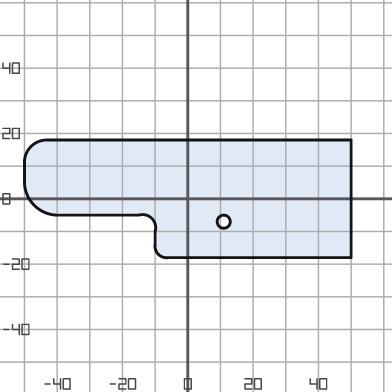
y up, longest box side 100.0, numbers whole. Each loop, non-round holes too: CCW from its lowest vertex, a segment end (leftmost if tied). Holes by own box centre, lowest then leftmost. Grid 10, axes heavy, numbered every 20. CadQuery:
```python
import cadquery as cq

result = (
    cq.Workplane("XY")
    .moveTo(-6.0, -18.0)
    .lineTo(50.0, -18.0)
    .lineTo(50.0, 18.0)
    .lineTo(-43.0, 18.0)
    .threePointArc((-48.0, 16.0), (-50.0, 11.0))
    .lineTo(-50.0, 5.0)
    .threePointArc((-47.0, -2.0), (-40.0, -5.0))
    .lineTo(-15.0, -5.0)
    .threePointArc((-11.0, -6.0), (-10.0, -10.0))
    .lineTo(-10.0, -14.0)
    .threePointArc((-9.0, -17.0), (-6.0, -18.0))
    .close()
    .moveTo(11.0, -7.0)
    .circle(2.0)
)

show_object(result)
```